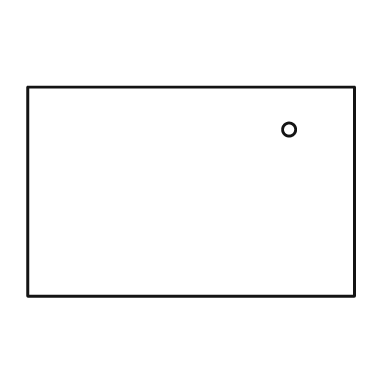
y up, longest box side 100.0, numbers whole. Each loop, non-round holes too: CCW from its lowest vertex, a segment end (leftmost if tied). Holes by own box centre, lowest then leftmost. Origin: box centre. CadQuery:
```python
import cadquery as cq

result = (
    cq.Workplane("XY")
    .moveTo(-50.0, -32.0)
    .lineTo(50.0, -32.0)
    .lineTo(50.0, 32.0)
    .lineTo(-50.0, 32.0)
    .close()
    .moveTo(30.0, 19.0)
    .circle(2.0)
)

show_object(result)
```